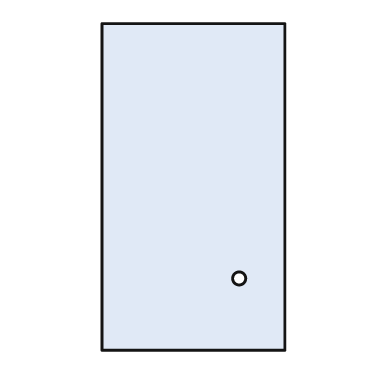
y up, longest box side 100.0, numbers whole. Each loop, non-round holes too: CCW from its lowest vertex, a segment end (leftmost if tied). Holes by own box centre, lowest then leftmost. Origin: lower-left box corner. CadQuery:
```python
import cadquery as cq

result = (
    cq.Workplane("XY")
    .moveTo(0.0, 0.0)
    .lineTo(56.0, 0.0)
    .lineTo(56.0, 100.0)
    .lineTo(0.0, 100.0)
    .close()
    .moveTo(42.0, 22.0)
    .circle(2.0)
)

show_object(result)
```